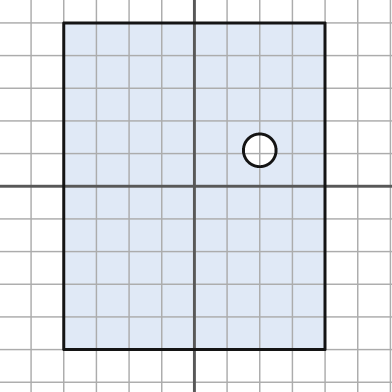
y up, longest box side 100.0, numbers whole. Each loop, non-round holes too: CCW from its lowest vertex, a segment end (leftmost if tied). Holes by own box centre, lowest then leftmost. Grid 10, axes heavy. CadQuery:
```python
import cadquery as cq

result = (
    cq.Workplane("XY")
    .moveTo(-40.0, -50.0)
    .lineTo(40.0, -50.0)
    .lineTo(40.0, 50.0)
    .lineTo(-40.0, 50.0)
    .close()
    .moveTo(20.0, 11.0)
    .circle(5.0)
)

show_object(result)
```